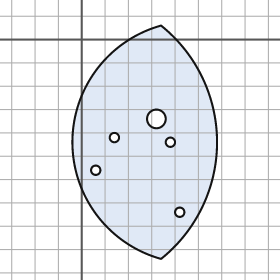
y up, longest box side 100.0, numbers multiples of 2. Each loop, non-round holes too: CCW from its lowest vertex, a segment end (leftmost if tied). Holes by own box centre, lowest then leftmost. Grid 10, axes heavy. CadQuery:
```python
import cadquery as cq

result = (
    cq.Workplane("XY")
    .moveTo(34.0, -94.0)
    .threePointArc((58.0, -44.0), (34.0, 6.0))
    .threePointArc((-4.0, -44.0), (34.0, -94.0))
    .close()
    .moveTo(42.0, -74.0)
    .circle(2.0)
    .moveTo(6.0, -56.0)
    .circle(2.0)
    .moveTo(38.0, -44.0)
    .circle(2.0)
    .moveTo(14.0, -42.0)
    .circle(2.0)
    .moveTo(32.0, -34.0)
    .circle(4.0)
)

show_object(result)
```